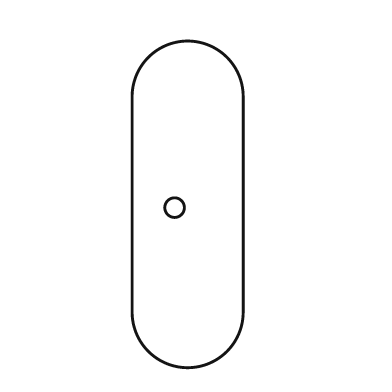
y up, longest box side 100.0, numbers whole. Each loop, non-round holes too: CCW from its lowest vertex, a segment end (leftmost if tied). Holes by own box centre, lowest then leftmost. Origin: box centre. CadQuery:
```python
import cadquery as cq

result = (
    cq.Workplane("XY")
    .moveTo(-17.0, -33.0)
    .threePointArc((0.0, -50.0), (17.0, -33.0))
    .lineTo(17.0, 33.0)
    .threePointArc((0.0, 50.0), (-17.0, 33.0))
    .close()
    .moveTo(-4.0, -1.0)
    .circle(3.0)
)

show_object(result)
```